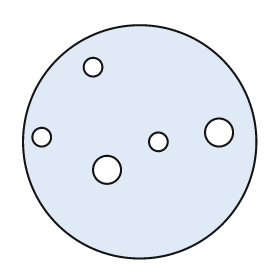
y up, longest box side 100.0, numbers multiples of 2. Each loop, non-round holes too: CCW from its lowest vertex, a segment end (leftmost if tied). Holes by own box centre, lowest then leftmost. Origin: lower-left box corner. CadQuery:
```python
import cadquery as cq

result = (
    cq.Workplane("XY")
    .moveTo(50.0, 50.0)
    .circle(50.0)
    .moveTo(36.0, 38.0)
    .circle(6.0)
    .moveTo(58.0, 50.0)
    .circle(4.0)
    .moveTo(8.0, 52.0)
    .circle(4.0)
    .moveTo(84.0, 54.0)
    .circle(6.0)
    .moveTo(30.0, 82.0)
    .circle(4.0)
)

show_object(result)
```